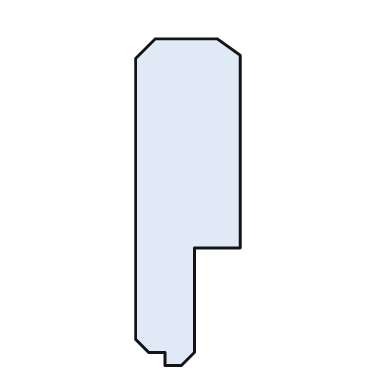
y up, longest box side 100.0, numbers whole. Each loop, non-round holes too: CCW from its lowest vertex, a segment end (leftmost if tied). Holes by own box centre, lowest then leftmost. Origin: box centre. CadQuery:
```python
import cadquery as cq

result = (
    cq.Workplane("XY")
    .moveTo(-7.0, -50.0)
    .lineTo(-2.0, -50.0)
    .lineTo(2.0, -46.0)
    .lineTo(2.0, -14.0)
    .lineTo(16.0, -14.0)
    .lineTo(16.0, 45.0)
    .lineTo(9.0, 50.0)
    .lineTo(-10.0, 50.0)
    .lineTo(-16.0, 44.0)
    .lineTo(-16.0, -42.0)
    .lineTo(-12.0, -46.0)
    .lineTo(-7.0, -46.0)
    .close()
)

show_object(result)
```